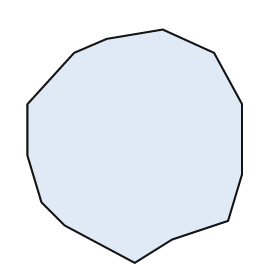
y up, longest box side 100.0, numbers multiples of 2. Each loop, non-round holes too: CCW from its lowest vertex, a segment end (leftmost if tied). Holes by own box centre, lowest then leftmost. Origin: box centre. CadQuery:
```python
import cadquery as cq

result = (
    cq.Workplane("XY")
    .moveTo(0.0, -50.0)
    .lineTo(16.0, -40.0)
    .lineTo(40.0, -32.0)
    .lineTo(46.0, -12.0)
    .lineTo(46.0, 18.0)
    .lineTo(34.0, 40.0)
    .lineTo(12.0, 50.0)
    .lineTo(-12.0, 46.0)
    .lineTo(-26.0, 40.0)
    .lineTo(-46.0, 18.0)
    .lineTo(-46.0, -4.0)
    .lineTo(-40.0, -24.0)
    .lineTo(-30.0, -34.0)
    .close()
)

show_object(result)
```